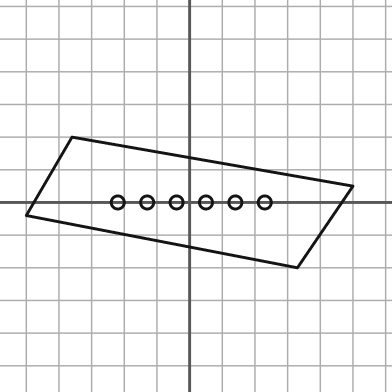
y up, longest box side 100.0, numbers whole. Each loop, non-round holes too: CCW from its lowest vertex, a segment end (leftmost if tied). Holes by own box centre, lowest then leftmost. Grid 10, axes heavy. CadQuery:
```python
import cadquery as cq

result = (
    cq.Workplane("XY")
    .moveTo(33.0, -20.0)
    .lineTo(50.0, 5.0)
    .lineTo(-36.0, 20.0)
    .lineTo(-50.0, -4.0)
    .close()
    .moveTo(-22.0, 0.0)
    .circle(2.0)
    .moveTo(-13.0, 0.0)
    .circle(2.0)
    .moveTo(-4.0, 0.0)
    .circle(2.0)
    .moveTo(5.0, 0.0)
    .circle(2.0)
    .moveTo(14.0, 0.0)
    .circle(2.0)
    .moveTo(23.0, 0.0)
    .circle(2.0)
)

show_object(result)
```